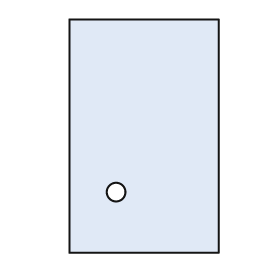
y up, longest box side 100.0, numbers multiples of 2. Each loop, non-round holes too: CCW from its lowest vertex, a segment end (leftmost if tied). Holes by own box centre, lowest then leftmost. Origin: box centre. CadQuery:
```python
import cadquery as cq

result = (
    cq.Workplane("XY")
    .moveTo(-32.0, -50.0)
    .lineTo(32.0, -50.0)
    .lineTo(32.0, 50.0)
    .lineTo(-32.0, 50.0)
    .close()
    .moveTo(-12.0, -24.0)
    .circle(4.0)
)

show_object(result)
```